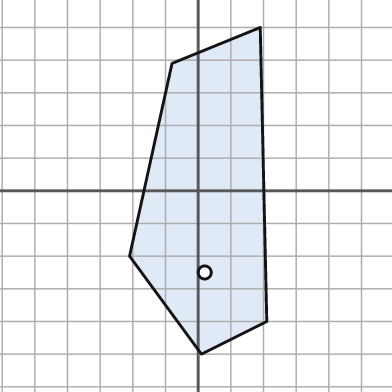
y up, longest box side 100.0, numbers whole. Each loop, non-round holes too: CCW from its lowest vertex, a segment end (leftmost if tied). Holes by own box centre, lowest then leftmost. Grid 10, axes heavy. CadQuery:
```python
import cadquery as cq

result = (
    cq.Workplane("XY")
    .moveTo(1.0, -50.0)
    .lineTo(21.0, -40.0)
    .lineTo(19.0, 50.0)
    .lineTo(-8.0, 39.0)
    .lineTo(-21.0, -20.0)
    .close()
    .moveTo(2.0, -25.0)
    .circle(2.0)
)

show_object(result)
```